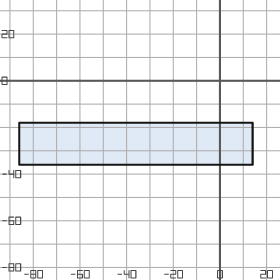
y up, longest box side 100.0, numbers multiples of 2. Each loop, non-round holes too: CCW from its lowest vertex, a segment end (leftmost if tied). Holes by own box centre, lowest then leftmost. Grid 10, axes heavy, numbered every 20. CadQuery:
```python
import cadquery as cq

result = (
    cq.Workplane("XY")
    .moveTo(-86.0, -36.0)
    .lineTo(14.0, -36.0)
    .lineTo(14.0, -18.0)
    .lineTo(-86.0, -18.0)
    .close()
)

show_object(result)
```